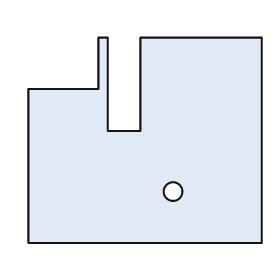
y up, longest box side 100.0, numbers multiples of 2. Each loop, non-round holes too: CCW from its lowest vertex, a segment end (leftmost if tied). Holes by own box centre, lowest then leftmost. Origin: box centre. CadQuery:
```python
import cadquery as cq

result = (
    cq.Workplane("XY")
    .moveTo(-50.0, -44.0)
    .lineTo(50.0, -44.0)
    .lineTo(50.0, 44.0)
    .lineTo(-2.0, 44.0)
    .lineTo(-2.0, 4.0)
    .lineTo(-16.0, 4.0)
    .lineTo(-16.0, 44.0)
    .lineTo(-20.0, 44.0)
    .lineTo(-20.0, 22.0)
    .lineTo(-50.0, 22.0)
    .close()
    .moveTo(12.0, -22.0)
    .circle(4.0)
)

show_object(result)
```